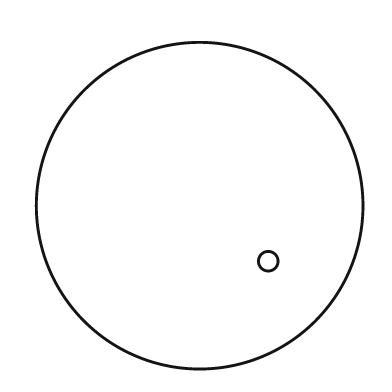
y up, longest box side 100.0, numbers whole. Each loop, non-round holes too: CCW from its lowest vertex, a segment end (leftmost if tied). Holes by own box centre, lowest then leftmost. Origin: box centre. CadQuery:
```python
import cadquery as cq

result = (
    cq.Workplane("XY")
    .moveTo(0.0, 0.0)
    .circle(50.0)
    .moveTo(21.0, -17.0)
    .circle(3.0)
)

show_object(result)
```